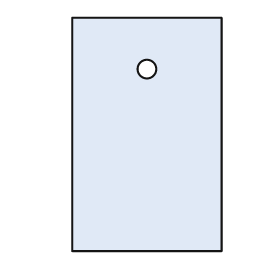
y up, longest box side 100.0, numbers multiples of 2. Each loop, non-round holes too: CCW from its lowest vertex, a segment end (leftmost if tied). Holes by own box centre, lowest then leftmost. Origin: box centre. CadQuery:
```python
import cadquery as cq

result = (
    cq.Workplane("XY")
    .moveTo(-32.0, -50.0)
    .lineTo(32.0, -50.0)
    .lineTo(32.0, 50.0)
    .lineTo(-32.0, 50.0)
    .close()
    .moveTo(0.0, 28.0)
    .circle(4.0)
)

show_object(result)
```